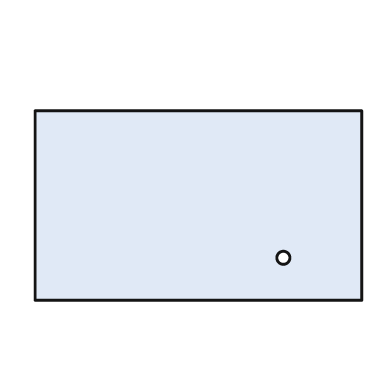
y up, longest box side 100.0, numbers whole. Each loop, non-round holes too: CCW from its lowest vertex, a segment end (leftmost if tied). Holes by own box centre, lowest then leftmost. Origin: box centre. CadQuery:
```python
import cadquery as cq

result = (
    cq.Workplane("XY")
    .moveTo(-50.0, -29.0)
    .lineTo(50.0, -29.0)
    .lineTo(50.0, 29.0)
    .lineTo(-50.0, 29.0)
    .close()
    .moveTo(26.0, -16.0)
    .circle(2.0)
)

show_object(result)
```